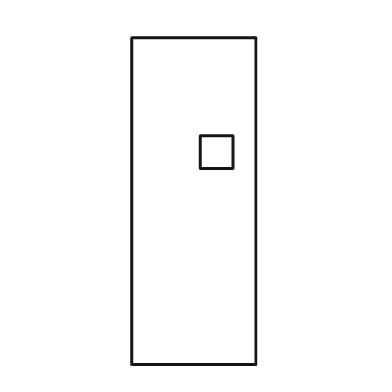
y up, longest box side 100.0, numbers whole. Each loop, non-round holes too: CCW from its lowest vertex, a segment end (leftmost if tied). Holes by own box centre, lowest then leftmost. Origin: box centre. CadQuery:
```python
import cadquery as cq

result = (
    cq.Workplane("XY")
    .moveTo(-19.0, -50.0)
    .lineTo(19.0, -50.0)
    .lineTo(19.0, 50.0)
    .lineTo(-19.0, 50.0)
    .close()
    .moveTo(2.0, 10.0)
    .lineTo(12.0, 10.0)
    .lineTo(12.0, 20.0)
    .lineTo(2.0, 20.0)
    .close()
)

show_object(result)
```